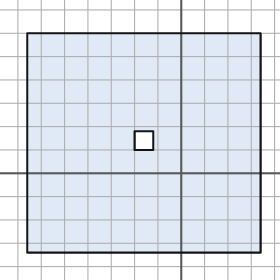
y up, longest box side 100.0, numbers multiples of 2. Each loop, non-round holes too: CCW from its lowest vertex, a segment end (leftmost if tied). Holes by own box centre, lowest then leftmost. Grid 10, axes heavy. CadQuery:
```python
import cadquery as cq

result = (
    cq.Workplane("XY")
    .moveTo(-66.0, -34.0)
    .lineTo(34.0, -34.0)
    .lineTo(34.0, 60.0)
    .lineTo(-66.0, 60.0)
    .close()
    .moveTo(-20.0, 10.0)
    .lineTo(-12.0, 10.0)
    .lineTo(-12.0, 18.0)
    .lineTo(-20.0, 18.0)
    .close()
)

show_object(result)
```